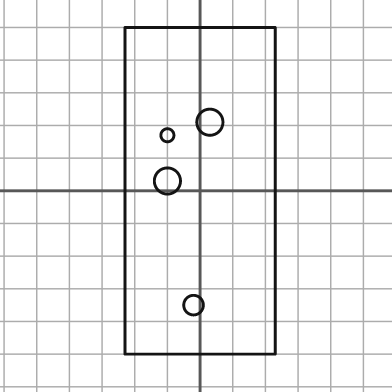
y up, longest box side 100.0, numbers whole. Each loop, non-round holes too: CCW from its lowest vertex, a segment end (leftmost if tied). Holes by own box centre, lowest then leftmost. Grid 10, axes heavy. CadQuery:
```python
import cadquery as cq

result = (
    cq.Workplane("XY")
    .moveTo(-23.0, -50.0)
    .lineTo(23.0, -50.0)
    .lineTo(23.0, 50.0)
    .lineTo(-23.0, 50.0)
    .close()
    .moveTo(-2.0, -35.0)
    .circle(3.0)
    .moveTo(-10.0, 3.0)
    .circle(4.0)
    .moveTo(-10.0, 17.0)
    .circle(2.0)
    .moveTo(3.0, 21.0)
    .circle(4.0)
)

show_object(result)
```